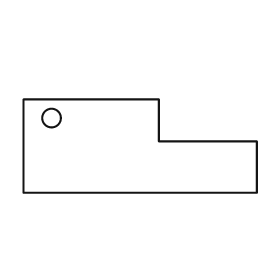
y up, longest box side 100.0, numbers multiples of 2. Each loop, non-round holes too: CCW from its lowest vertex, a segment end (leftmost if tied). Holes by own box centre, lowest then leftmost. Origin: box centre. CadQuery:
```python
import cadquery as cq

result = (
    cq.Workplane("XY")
    .moveTo(-50.0, -20.0)
    .lineTo(50.0, -20.0)
    .lineTo(50.0, 2.0)
    .lineTo(8.0, 2.0)
    .lineTo(8.0, 20.0)
    .lineTo(-50.0, 20.0)
    .close()
    .moveTo(-38.0, 12.0)
    .circle(4.0)
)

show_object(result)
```